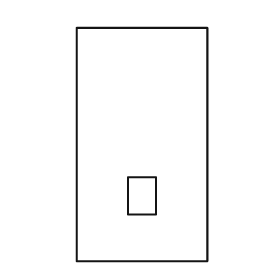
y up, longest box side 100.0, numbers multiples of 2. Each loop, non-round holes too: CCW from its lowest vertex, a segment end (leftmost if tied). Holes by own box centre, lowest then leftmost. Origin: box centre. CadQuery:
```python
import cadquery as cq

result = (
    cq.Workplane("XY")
    .moveTo(-28.0, -50.0)
    .lineTo(28.0, -50.0)
    .lineTo(28.0, 50.0)
    .lineTo(-28.0, 50.0)
    .close()
    .moveTo(-6.0, -30.0)
    .lineTo(6.0, -30.0)
    .lineTo(6.0, -14.0)
    .lineTo(-6.0, -14.0)
    .close()
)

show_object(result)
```